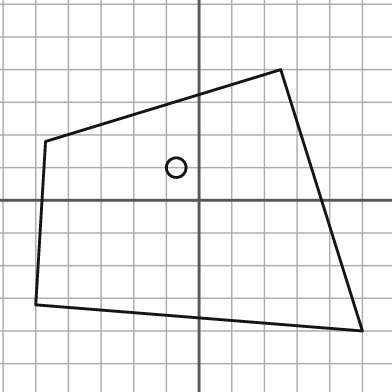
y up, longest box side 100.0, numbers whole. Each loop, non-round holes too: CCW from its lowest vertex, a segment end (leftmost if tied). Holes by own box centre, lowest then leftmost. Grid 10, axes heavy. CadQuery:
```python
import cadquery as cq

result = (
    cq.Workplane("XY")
    .moveTo(50.0, -40.0)
    .lineTo(25.0, 40.0)
    .lineTo(-47.0, 18.0)
    .lineTo(-50.0, -32.0)
    .close()
    .moveTo(-7.0, 10.0)
    .circle(3.0)
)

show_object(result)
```